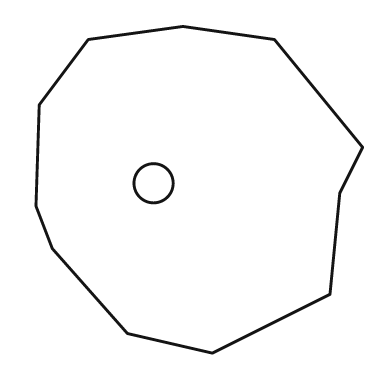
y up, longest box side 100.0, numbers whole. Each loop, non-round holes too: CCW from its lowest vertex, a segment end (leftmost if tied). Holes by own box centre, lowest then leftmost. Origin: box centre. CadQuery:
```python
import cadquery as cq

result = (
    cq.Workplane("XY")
    .moveTo(4.0, -50.0)
    .lineTo(40.0, -32.0)
    .lineTo(43.0, -1.0)
    .lineTo(50.0, 13.0)
    .lineTo(23.0, 46.0)
    .lineTo(-5.0, 50.0)
    .lineTo(-34.0, 46.0)
    .lineTo(-49.0, 26.0)
    .lineTo(-50.0, -5.0)
    .lineTo(-45.0, -18.0)
    .lineTo(-22.0, -44.0)
    .close()
    .moveTo(-14.0, 2.0)
    .circle(6.0)
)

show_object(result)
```